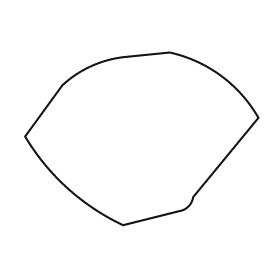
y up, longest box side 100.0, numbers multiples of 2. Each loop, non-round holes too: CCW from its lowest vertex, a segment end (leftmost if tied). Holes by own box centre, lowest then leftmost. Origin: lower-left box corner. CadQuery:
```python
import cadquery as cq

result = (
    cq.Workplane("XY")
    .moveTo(42.0, 0.0)
    .lineTo(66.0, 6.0)
    .threePointArc((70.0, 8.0), (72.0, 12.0))
    .lineTo(100.0, 46.0)
    .threePointArc((84.0, 64.0), (62.0, 74.0))
    .lineTo(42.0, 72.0)
    .threePointArc((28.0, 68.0), (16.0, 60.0))
    .lineTo(0.0, 38.0)
    .threePointArc((18.0, 16.0), (42.0, 0.0))
    .close()
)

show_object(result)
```